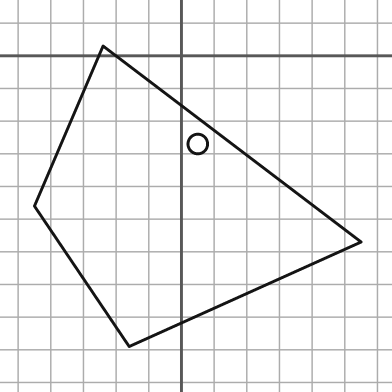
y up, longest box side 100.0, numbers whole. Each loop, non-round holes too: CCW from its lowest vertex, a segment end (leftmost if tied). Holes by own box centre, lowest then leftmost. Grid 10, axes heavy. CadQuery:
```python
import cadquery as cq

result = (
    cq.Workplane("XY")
    .moveTo(-16.0, -89.0)
    .lineTo(55.0, -57.0)
    .lineTo(-24.0, 3.0)
    .lineTo(-45.0, -46.0)
    .close()
    .moveTo(5.0, -27.0)
    .circle(3.0)
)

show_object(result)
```